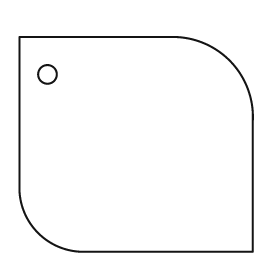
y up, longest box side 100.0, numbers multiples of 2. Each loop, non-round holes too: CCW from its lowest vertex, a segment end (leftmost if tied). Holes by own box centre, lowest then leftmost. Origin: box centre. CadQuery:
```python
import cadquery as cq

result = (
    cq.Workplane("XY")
    .moveTo(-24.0, -46.0)
    .lineTo(50.0, -46.0)
    .lineTo(50.0, 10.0)
    .threePointArc((40.0, 36.0), (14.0, 46.0))
    .lineTo(-50.0, 46.0)
    .lineTo(-50.0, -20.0)
    .threePointArc((-42.0, -38.0), (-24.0, -46.0))
    .close()
    .moveTo(-38.0, 30.0)
    .circle(4.0)
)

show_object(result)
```